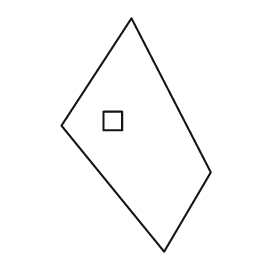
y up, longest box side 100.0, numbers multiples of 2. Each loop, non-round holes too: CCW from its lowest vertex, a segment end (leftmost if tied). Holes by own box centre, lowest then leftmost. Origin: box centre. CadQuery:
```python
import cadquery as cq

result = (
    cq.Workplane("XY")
    .moveTo(12.0, -50.0)
    .lineTo(32.0, -16.0)
    .lineTo(-2.0, 50.0)
    .lineTo(-32.0, 4.0)
    .close()
    .moveTo(-14.0, 2.0)
    .lineTo(-6.0, 2.0)
    .lineTo(-6.0, 10.0)
    .lineTo(-14.0, 10.0)
    .close()
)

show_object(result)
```